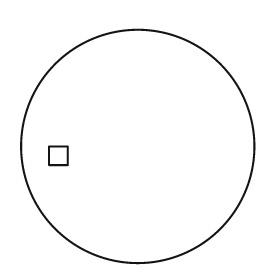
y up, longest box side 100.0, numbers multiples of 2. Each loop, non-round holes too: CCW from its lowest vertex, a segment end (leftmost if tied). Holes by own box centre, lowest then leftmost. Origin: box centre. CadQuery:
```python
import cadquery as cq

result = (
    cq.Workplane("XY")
    .moveTo(0.0, 0.0)
    .circle(50.0)
    .moveTo(-38.0, -8.0)
    .lineTo(-30.0, -8.0)
    .lineTo(-30.0, 0.0)
    .lineTo(-38.0, 0.0)
    .close()
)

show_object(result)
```